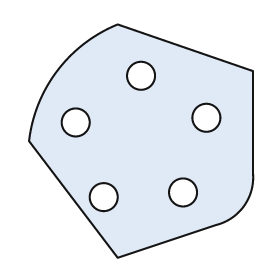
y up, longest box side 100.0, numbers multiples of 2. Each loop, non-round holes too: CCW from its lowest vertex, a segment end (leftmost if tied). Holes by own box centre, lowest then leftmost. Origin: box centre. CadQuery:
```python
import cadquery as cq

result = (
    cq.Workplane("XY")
    .moveTo(-10.0, -50.0)
    .lineTo(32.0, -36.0)
    .threePointArc((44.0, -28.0), (48.0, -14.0))
    .lineTo(48.0, 30.0)
    .lineTo(-10.0, 50.0)
    .threePointArc((-36.0, 30.0), (-48.0, 0.0))
    .close()
    .moveTo(-16.0, -24.0)
    .circle(6.0)
    .moveTo(18.0, -22.0)
    .circle(6.0)
    .moveTo(-28.0, 8.0)
    .circle(6.0)
    .moveTo(28.0, 10.0)
    .circle(6.0)
    .moveTo(0.0, 28.0)
    .circle(6.0)
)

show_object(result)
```